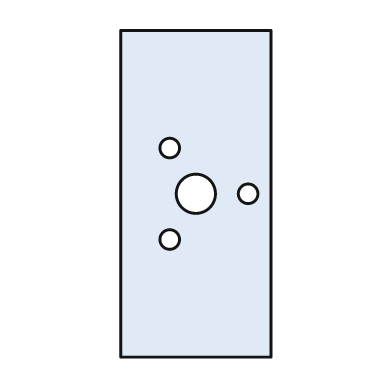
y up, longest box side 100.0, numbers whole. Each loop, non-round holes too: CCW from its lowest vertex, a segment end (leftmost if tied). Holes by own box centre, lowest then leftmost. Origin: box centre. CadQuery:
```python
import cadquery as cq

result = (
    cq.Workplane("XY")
    .moveTo(-23.0, -50.0)
    .lineTo(23.0, -50.0)
    .lineTo(23.0, 50.0)
    .lineTo(-23.0, 50.0)
    .close()
    .moveTo(-8.0, -14.0)
    .circle(3.0)
    .moveTo(0.0, 0.0)
    .circle(6.0)
    .moveTo(16.0, 0.0)
    .circle(3.0)
    .moveTo(-8.0, 14.0)
    .circle(3.0)
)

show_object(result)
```